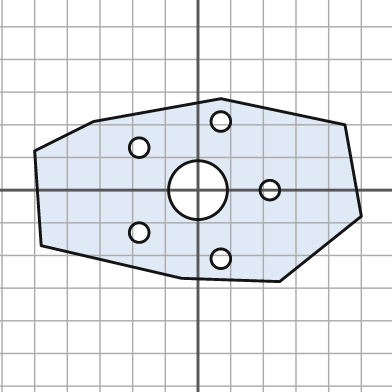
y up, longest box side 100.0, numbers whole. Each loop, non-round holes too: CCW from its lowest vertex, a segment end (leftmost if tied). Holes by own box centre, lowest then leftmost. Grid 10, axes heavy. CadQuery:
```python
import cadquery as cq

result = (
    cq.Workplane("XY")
    .moveTo(25.0, -28.0)
    .lineTo(50.0, -8.0)
    .lineTo(45.0, 20.0)
    .lineTo(7.0, 28.0)
    .lineTo(-32.0, 21.0)
    .lineTo(-50.0, 12.0)
    .lineTo(-48.0, -17.0)
    .lineTo(-5.0, -27.0)
    .close()
    .moveTo(7.0, -21.0)
    .circle(3.0)
    .moveTo(-18.0, -13.0)
    .circle(3.0)
    .moveTo(0.0, 0.0)
    .circle(9.0)
    .moveTo(22.0, 0.0)
    .circle(3.0)
    .moveTo(-18.0, 13.0)
    .circle(3.0)
    .moveTo(7.0, 21.0)
    .circle(3.0)
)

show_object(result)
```